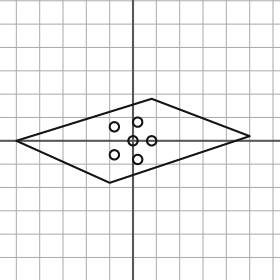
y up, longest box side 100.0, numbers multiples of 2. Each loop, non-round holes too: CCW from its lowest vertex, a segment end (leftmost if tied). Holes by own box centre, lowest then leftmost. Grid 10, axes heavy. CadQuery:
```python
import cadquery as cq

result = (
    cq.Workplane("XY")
    .moveTo(-10.0, -18.0)
    .lineTo(50.0, 2.0)
    .lineTo(8.0, 18.0)
    .lineTo(-50.0, 0.0)
    .close()
    .moveTo(2.0, -8.0)
    .circle(2.0)
    .moveTo(-8.0, -6.0)
    .circle(2.0)
    .moveTo(0.0, 0.0)
    .circle(2.0)
    .moveTo(8.0, 0.0)
    .circle(2.0)
    .moveTo(-8.0, 6.0)
    .circle(2.0)
    .moveTo(2.0, 8.0)
    .circle(2.0)
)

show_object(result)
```